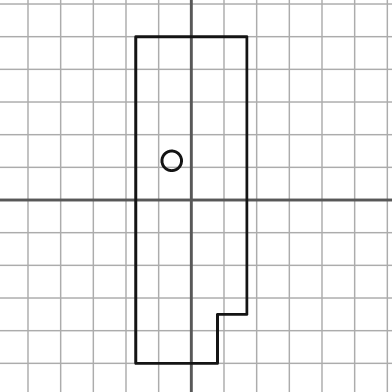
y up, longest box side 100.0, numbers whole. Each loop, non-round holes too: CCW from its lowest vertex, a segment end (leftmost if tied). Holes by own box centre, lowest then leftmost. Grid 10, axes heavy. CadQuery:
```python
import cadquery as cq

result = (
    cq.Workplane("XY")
    .moveTo(-17.0, -50.0)
    .lineTo(8.0, -50.0)
    .lineTo(8.0, -35.0)
    .lineTo(17.0, -35.0)
    .lineTo(17.0, 50.0)
    .lineTo(-17.0, 50.0)
    .close()
    .moveTo(-6.0, 12.0)
    .circle(3.0)
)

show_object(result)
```